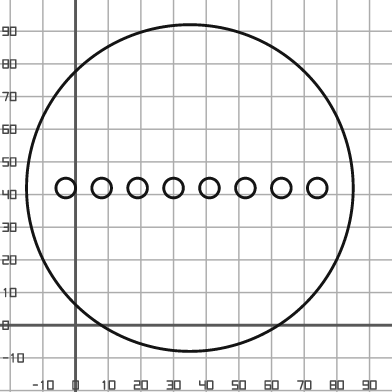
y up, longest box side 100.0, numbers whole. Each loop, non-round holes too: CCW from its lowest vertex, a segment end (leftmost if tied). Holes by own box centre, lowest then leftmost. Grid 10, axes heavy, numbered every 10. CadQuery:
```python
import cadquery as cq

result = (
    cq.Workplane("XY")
    .moveTo(35.0, 42.0)
    .circle(50.0)
    .moveTo(-3.0, 42.0)
    .circle(3.0)
    .moveTo(8.0, 42.0)
    .circle(3.0)
    .moveTo(19.0, 42.0)
    .circle(3.0)
    .moveTo(30.0, 42.0)
    .circle(3.0)
    .moveTo(41.0, 42.0)
    .circle(3.0)
    .moveTo(52.0, 42.0)
    .circle(3.0)
    .moveTo(63.0, 42.0)
    .circle(3.0)
    .moveTo(74.0, 42.0)
    .circle(3.0)
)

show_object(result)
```